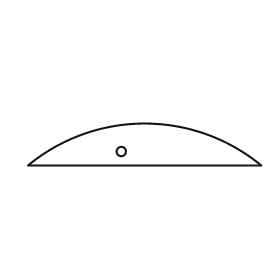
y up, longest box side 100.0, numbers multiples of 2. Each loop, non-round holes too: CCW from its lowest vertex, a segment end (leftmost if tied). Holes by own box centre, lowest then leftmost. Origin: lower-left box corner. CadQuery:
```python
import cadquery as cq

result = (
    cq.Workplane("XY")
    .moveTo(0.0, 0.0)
    .lineTo(100.0, 0.0)
    .threePointArc((50.0, 18.0), (0.0, 0.0))
    .close()
    .moveTo(40.0, 6.0)
    .circle(2.0)
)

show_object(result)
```